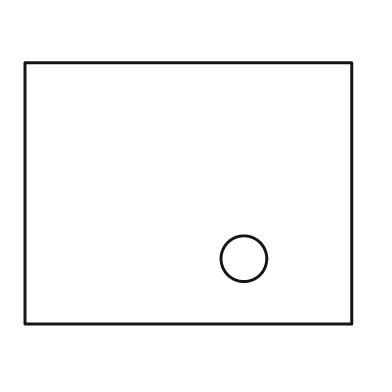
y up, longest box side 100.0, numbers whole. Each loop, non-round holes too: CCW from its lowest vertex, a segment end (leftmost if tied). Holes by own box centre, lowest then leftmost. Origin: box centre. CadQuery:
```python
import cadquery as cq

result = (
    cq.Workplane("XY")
    .moveTo(-50.0, -40.0)
    .lineTo(50.0, -40.0)
    .lineTo(50.0, 40.0)
    .lineTo(-50.0, 40.0)
    .close()
    .moveTo(17.0, -20.0)
    .circle(7.0)
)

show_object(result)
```